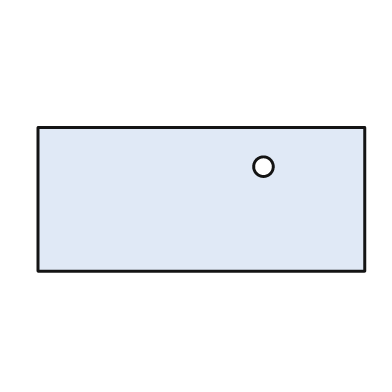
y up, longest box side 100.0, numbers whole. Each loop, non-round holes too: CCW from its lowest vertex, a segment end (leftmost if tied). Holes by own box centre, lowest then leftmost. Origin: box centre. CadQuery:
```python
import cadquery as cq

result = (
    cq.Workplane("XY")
    .moveTo(-50.0, -22.0)
    .lineTo(50.0, -22.0)
    .lineTo(50.0, 22.0)
    .lineTo(-50.0, 22.0)
    .close()
    .moveTo(19.0, 10.0)
    .circle(3.0)
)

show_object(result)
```